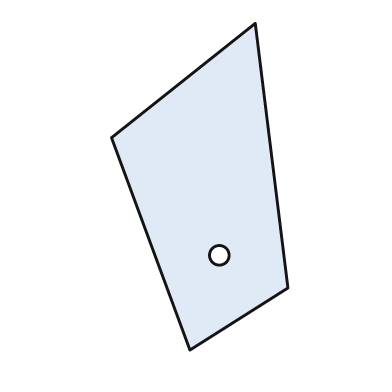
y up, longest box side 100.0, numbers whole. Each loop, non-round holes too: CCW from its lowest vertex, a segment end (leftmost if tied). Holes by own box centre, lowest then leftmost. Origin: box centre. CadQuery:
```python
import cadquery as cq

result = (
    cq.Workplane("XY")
    .moveTo(-3.0, -50.0)
    .lineTo(27.0, -31.0)
    .lineTo(17.0, 50.0)
    .lineTo(-27.0, 15.0)
    .close()
    .moveTo(6.0, -21.0)
    .circle(3.0)
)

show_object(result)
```